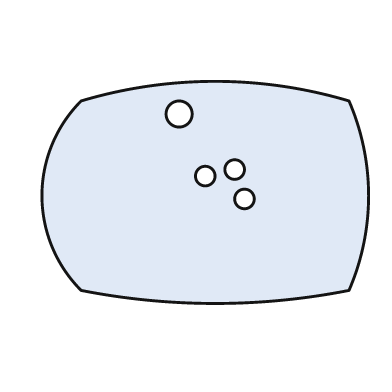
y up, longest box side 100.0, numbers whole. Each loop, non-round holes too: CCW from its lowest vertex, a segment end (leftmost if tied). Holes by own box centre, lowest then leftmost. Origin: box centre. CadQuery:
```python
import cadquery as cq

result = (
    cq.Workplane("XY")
    .moveTo(-38.0, -30.0)
    .threePointArc((3.0, -34.0), (44.0, -30.0))
    .threePointArc((50.0, -1.0), (44.0, 28.0))
    .threePointArc((3.0, 34.0), (-38.0, 28.0))
    .threePointArc((-50.0, -1.0), (-38.0, -30.0))
    .close()
    .moveTo(12.0, -2.0)
    .circle(3.0)
    .moveTo(0.0, 5.0)
    .circle(3.0)
    .moveTo(9.0, 7.0)
    .circle(3.0)
    .moveTo(-8.0, 24.0)
    .circle(4.0)
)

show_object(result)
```